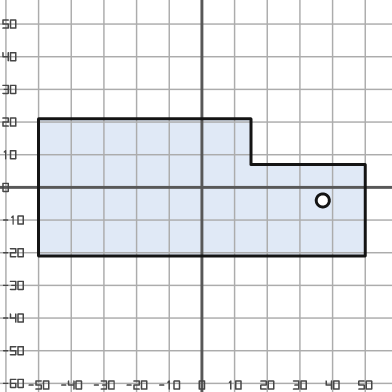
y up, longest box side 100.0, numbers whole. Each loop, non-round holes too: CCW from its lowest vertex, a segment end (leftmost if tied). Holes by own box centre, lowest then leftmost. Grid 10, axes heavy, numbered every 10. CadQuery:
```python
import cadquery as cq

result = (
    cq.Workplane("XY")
    .moveTo(-50.0, -21.0)
    .lineTo(50.0, -21.0)
    .lineTo(50.0, 7.0)
    .lineTo(15.0, 7.0)
    .lineTo(15.0, 21.0)
    .lineTo(-50.0, 21.0)
    .close()
    .moveTo(37.0, -4.0)
    .circle(2.0)
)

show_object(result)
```